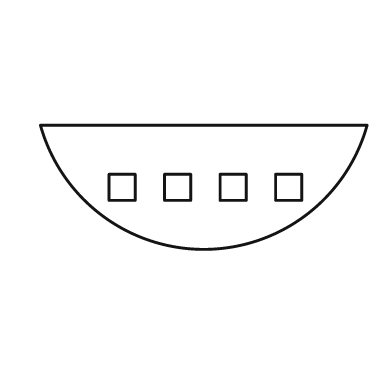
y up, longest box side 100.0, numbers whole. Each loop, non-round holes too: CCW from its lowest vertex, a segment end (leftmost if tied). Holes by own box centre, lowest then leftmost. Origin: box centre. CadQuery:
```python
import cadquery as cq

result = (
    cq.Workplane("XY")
    .moveTo(-50.0, 19.0)
    .threePointArc((0.0, -19.0), (50.0, 19.0))
    .close()
    .moveTo(-29.0, -4.0)
    .lineTo(-21.0, -4.0)
    .lineTo(-21.0, 4.0)
    .lineTo(-29.0, 4.0)
    .close()
    .moveTo(-12.0, -4.0)
    .lineTo(-4.0, -4.0)
    .lineTo(-4.0, 4.0)
    .lineTo(-12.0, 4.0)
    .close()
    .moveTo(5.0, -4.0)
    .lineTo(13.0, -4.0)
    .lineTo(13.0, 4.0)
    .lineTo(5.0, 4.0)
    .close()
    .moveTo(22.0, -4.0)
    .lineTo(30.0, -4.0)
    .lineTo(30.0, 4.0)
    .lineTo(22.0, 4.0)
    .close()
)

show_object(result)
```